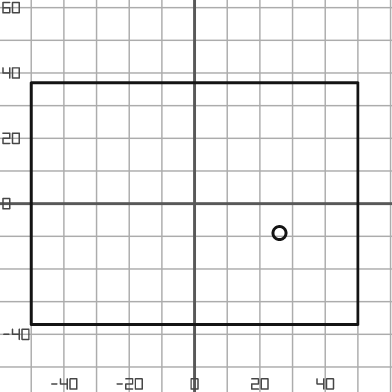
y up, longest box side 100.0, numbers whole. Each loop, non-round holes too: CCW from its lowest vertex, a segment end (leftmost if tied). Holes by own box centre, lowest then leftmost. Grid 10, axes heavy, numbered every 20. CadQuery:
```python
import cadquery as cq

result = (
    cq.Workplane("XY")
    .moveTo(-50.0, -37.0)
    .lineTo(50.0, -37.0)
    .lineTo(50.0, 37.0)
    .lineTo(-50.0, 37.0)
    .close()
    .moveTo(26.0, -9.0)
    .circle(2.0)
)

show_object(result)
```